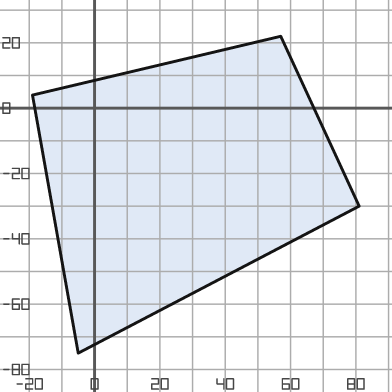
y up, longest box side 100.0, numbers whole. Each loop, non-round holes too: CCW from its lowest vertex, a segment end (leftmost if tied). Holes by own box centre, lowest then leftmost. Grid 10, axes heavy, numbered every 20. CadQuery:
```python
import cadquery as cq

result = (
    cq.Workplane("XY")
    .moveTo(-5.0, -75.0)
    .lineTo(81.0, -30.0)
    .lineTo(57.0, 22.0)
    .lineTo(-19.0, 4.0)
    .close()
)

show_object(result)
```